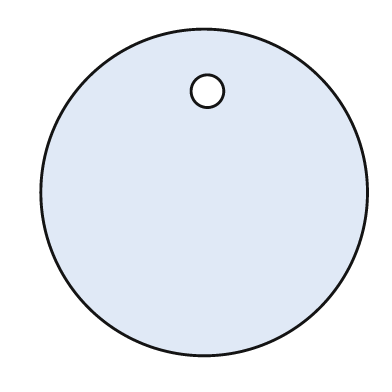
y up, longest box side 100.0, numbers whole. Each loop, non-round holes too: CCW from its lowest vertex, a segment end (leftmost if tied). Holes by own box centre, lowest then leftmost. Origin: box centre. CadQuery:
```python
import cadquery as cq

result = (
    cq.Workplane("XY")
    .moveTo(0.0, 0.0)
    .circle(50.0)
    .moveTo(1.0, 31.0)
    .circle(5.0)
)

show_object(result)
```